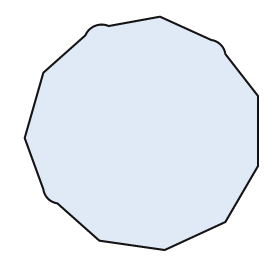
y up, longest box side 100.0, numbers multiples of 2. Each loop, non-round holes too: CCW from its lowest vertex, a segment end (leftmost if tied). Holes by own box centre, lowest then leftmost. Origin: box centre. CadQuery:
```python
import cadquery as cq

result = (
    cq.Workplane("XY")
    .moveTo(10.0, -50.0)
    .lineTo(36.0, -38.0)
    .lineTo(50.0, -14.0)
    .lineTo(50.0, 16.0)
    .lineTo(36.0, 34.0)
    .threePointArc((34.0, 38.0), (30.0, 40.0))
    .lineTo(8.0, 50.0)
    .lineTo(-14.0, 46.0)
    .threePointArc((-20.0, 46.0), (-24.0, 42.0))
    .lineTo(-42.0, 26.0)
    .lineTo(-50.0, -2.0)
    .lineTo(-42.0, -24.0)
    .threePointArc((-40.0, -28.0), (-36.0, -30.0))
    .lineTo(-18.0, -46.0)
    .close()
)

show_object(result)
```